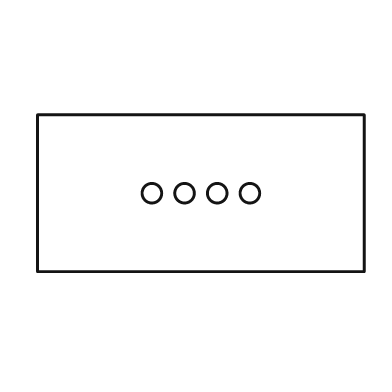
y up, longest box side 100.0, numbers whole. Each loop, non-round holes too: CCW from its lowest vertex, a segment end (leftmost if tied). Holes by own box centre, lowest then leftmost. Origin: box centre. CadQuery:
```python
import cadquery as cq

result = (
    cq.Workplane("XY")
    .moveTo(-50.0, -24.0)
    .lineTo(50.0, -24.0)
    .lineTo(50.0, 24.0)
    .lineTo(-50.0, 24.0)
    .close()
    .moveTo(-15.0, 0.0)
    .circle(3.0)
    .moveTo(-5.0, 0.0)
    .circle(3.0)
    .moveTo(5.0, 0.0)
    .circle(3.0)
    .moveTo(15.0, 0.0)
    .circle(3.0)
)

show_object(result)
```